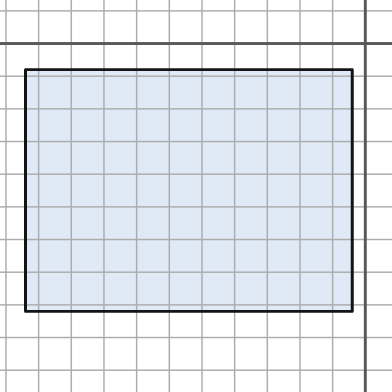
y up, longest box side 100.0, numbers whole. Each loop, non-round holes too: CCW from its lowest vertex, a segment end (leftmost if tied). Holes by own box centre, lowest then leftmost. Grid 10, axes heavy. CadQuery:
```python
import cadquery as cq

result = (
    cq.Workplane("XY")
    .moveTo(-104.0, -82.0)
    .lineTo(-4.0, -82.0)
    .lineTo(-4.0, -8.0)
    .lineTo(-104.0, -8.0)
    .close()
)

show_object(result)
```